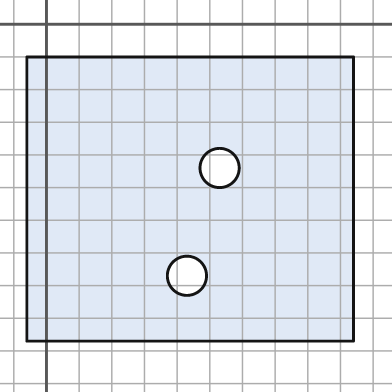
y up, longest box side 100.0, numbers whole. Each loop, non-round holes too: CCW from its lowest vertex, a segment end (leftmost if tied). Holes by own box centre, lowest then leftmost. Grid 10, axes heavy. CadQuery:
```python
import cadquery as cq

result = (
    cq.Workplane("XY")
    .moveTo(-6.0, -97.0)
    .lineTo(94.0, -97.0)
    .lineTo(94.0, -10.0)
    .lineTo(-6.0, -10.0)
    .close()
    .moveTo(43.0, -77.0)
    .circle(6.0)
    .moveTo(53.0, -44.0)
    .circle(6.0)
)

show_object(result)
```